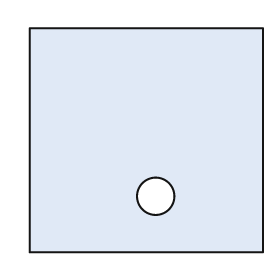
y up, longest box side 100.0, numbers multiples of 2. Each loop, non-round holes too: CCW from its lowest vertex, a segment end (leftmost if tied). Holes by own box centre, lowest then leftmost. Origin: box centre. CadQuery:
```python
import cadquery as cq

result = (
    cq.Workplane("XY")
    .moveTo(-50.0, -48.0)
    .lineTo(50.0, -48.0)
    .lineTo(50.0, 48.0)
    .lineTo(-50.0, 48.0)
    .close()
    .moveTo(4.0, -24.0)
    .circle(8.0)
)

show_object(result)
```